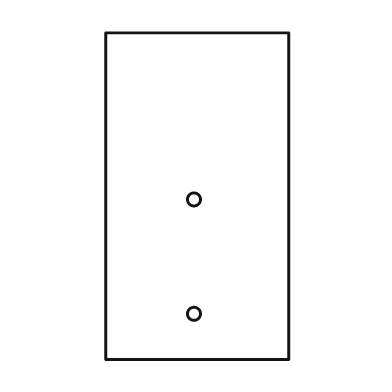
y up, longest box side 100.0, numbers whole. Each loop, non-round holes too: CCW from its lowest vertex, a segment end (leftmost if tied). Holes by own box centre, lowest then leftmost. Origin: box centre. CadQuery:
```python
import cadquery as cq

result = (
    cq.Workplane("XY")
    .moveTo(-28.0, -50.0)
    .lineTo(28.0, -50.0)
    .lineTo(28.0, 50.0)
    .lineTo(-28.0, 50.0)
    .close()
    .moveTo(-1.0, -36.0)
    .circle(2.0)
    .moveTo(-1.0, -1.0)
    .circle(2.0)
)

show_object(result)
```